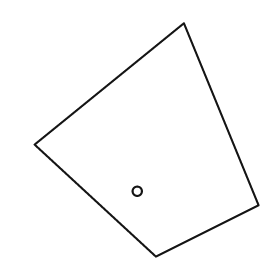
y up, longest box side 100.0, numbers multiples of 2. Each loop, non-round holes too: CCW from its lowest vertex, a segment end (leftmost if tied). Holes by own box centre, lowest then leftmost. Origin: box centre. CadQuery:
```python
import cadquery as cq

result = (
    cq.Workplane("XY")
    .moveTo(4.0, -50.0)
    .lineTo(48.0, -28.0)
    .lineTo(16.0, 50.0)
    .lineTo(-48.0, -2.0)
    .close()
    .moveTo(-4.0, -22.0)
    .circle(2.0)
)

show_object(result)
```